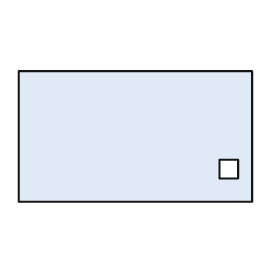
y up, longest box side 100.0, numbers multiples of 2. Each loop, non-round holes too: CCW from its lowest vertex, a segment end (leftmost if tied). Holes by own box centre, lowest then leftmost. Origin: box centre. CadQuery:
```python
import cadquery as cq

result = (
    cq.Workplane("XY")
    .moveTo(-50.0, -28.0)
    .lineTo(50.0, -28.0)
    .lineTo(50.0, 28.0)
    .lineTo(-50.0, 28.0)
    .close()
    .moveTo(36.0, -18.0)
    .lineTo(44.0, -18.0)
    .lineTo(44.0, -10.0)
    .lineTo(36.0, -10.0)
    .close()
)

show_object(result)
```